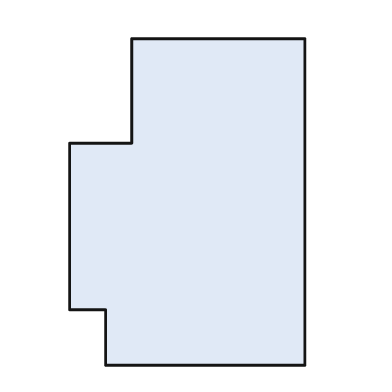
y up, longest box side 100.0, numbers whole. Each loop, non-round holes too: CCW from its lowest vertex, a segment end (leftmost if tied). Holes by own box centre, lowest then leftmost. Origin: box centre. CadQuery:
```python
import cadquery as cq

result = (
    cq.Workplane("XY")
    .moveTo(-25.0, -50.0)
    .lineTo(36.0, -50.0)
    .lineTo(36.0, 50.0)
    .lineTo(-17.0, 50.0)
    .lineTo(-17.0, 18.0)
    .lineTo(-36.0, 18.0)
    .lineTo(-36.0, -33.0)
    .lineTo(-25.0, -33.0)
    .close()
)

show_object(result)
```